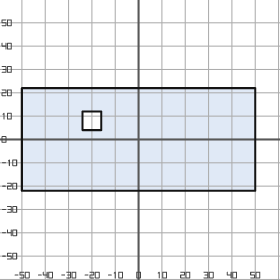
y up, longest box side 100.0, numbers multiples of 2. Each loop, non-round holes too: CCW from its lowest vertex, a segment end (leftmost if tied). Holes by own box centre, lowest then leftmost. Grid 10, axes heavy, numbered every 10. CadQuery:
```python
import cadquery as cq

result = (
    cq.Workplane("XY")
    .moveTo(-50.0, -22.0)
    .lineTo(50.0, -22.0)
    .lineTo(50.0, 22.0)
    .lineTo(-50.0, 22.0)
    .close()
    .moveTo(-24.0, 4.0)
    .lineTo(-16.0, 4.0)
    .lineTo(-16.0, 12.0)
    .lineTo(-24.0, 12.0)
    .close()
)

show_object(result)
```